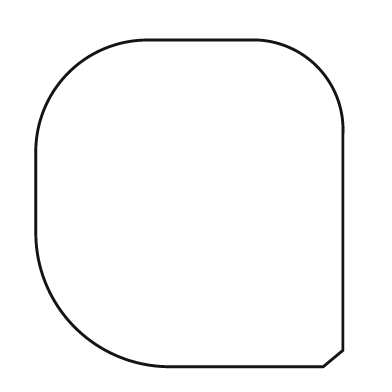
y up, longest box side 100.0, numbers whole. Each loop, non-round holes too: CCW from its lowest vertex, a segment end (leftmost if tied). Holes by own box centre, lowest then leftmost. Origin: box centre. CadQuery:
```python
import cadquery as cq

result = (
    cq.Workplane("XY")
    .moveTo(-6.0, -50.0)
    .lineTo(41.0, -50.0)
    .lineTo(47.0, -45.0)
    .lineTo(47.0, 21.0)
    .threePointArc((39.0, 42.0), (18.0, 50.0))
    .lineTo(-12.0, 50.0)
    .threePointArc((-37.0, 40.0), (-47.0, 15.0))
    .lineTo(-47.0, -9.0)
    .threePointArc((-35.0, -38.0), (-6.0, -50.0))
    .close()
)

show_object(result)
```